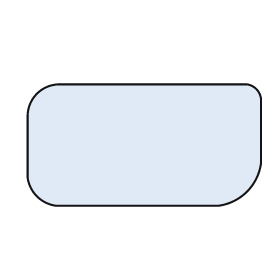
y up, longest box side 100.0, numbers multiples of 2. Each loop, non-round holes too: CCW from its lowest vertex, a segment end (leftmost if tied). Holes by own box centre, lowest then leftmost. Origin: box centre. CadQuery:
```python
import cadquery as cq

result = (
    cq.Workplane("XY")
    .moveTo(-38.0, -26.0)
    .lineTo(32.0, -26.0)
    .threePointArc((44.0, -20.0), (50.0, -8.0))
    .lineTo(50.0, 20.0)
    .threePointArc((48.0, 24.0), (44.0, 26.0))
    .lineTo(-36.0, 26.0)
    .threePointArc((-46.0, 22.0), (-50.0, 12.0))
    .lineTo(-50.0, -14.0)
    .threePointArc((-46.0, -22.0), (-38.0, -26.0))
    .close()
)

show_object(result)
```